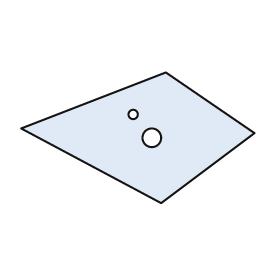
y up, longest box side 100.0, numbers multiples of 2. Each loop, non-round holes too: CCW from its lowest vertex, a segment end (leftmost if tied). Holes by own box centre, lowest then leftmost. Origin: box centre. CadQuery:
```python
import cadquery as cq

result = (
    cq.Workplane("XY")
    .moveTo(10.0, -28.0)
    .lineTo(50.0, 2.0)
    .lineTo(12.0, 28.0)
    .lineTo(-50.0, 4.0)
    .close()
    .moveTo(6.0, 0.0)
    .circle(4.0)
    .moveTo(-2.0, 10.0)
    .circle(2.0)
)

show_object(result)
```